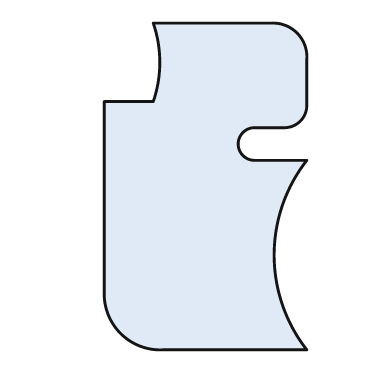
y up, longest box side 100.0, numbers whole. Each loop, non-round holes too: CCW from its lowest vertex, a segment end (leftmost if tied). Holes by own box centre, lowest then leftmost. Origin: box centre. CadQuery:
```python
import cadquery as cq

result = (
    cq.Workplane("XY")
    .moveTo(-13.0, -50.0)
    .lineTo(31.0, -50.0)
    .threePointArc((21.0, -21.0), (31.0, 8.0))
    .lineTo(15.0, 8.0)
    .threePointArc((10.0, 13.0), (15.0, 18.0))
    .lineTo(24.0, 18.0)
    .threePointArc((29.0, 20.0), (31.0, 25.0))
    .lineTo(31.0, 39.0)
    .threePointArc((28.0, 47.0), (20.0, 50.0))
    .lineTo(-16.0, 50.0)
    .threePointArc((-14.0, 38.0), (-16.0, 26.0))
    .lineTo(-31.0, 26.0)
    .lineTo(-31.0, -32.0)
    .threePointArc((-26.0, -45.0), (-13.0, -50.0))
    .close()
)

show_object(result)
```